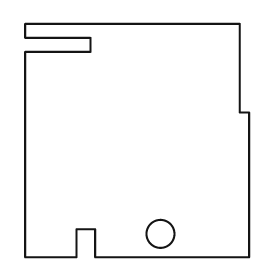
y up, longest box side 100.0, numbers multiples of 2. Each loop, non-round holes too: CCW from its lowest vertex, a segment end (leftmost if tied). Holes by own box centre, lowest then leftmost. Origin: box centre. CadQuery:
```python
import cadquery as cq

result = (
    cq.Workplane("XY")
    .moveTo(-48.0, -50.0)
    .lineTo(-26.0, -50.0)
    .lineTo(-26.0, -38.0)
    .lineTo(-18.0, -38.0)
    .lineTo(-18.0, -50.0)
    .lineTo(48.0, -50.0)
    .lineTo(48.0, 12.0)
    .lineTo(44.0, 12.0)
    .lineTo(44.0, 50.0)
    .lineTo(-48.0, 50.0)
    .lineTo(-48.0, 44.0)
    .lineTo(-20.0, 44.0)
    .lineTo(-20.0, 38.0)
    .lineTo(-48.0, 38.0)
    .close()
    .moveTo(10.0, -40.0)
    .circle(6.0)
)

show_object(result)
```